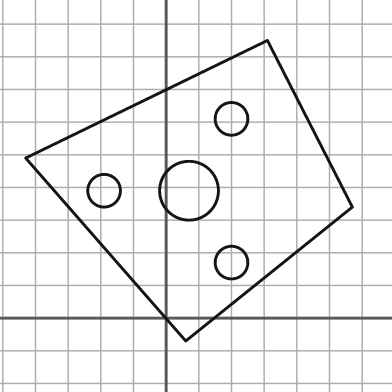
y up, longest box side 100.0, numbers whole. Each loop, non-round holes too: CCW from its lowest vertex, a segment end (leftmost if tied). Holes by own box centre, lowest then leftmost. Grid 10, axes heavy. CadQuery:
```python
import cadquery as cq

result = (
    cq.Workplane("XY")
    .moveTo(6.0, -7.0)
    .lineTo(57.0, 34.0)
    .lineTo(31.0, 85.0)
    .lineTo(-43.0, 49.0)
    .close()
    .moveTo(20.0, 17.0)
    .circle(5.0)
    .moveTo(-19.0, 39.0)
    .circle(5.0)
    .moveTo(7.0, 39.0)
    .circle(9.0)
    .moveTo(20.0, 61.0)
    .circle(5.0)
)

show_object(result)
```